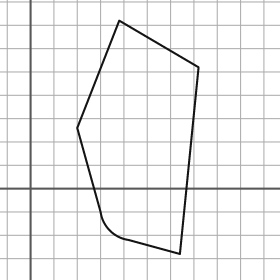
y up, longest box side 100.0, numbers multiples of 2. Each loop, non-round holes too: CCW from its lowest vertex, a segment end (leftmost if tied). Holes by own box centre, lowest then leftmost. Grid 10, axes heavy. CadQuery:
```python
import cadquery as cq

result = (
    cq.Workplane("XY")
    .moveTo(64.0, -28.0)
    .lineTo(72.0, 52.0)
    .lineTo(38.0, 72.0)
    .lineTo(20.0, 26.0)
    .lineTo(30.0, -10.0)
    .threePointArc((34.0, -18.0), (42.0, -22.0))
    .close()
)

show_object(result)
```